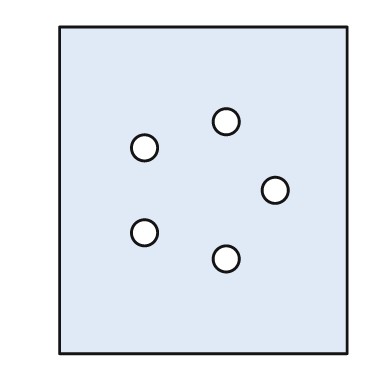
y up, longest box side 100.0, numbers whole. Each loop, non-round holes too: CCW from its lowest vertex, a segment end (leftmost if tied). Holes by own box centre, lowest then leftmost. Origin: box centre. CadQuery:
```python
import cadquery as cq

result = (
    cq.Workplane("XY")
    .moveTo(-44.0, -50.0)
    .lineTo(44.0, -50.0)
    .lineTo(44.0, 50.0)
    .lineTo(-44.0, 50.0)
    .close()
    .moveTo(7.0, -21.0)
    .circle(4.0)
    .moveTo(-18.0, -13.0)
    .circle(4.0)
    .moveTo(22.0, 0.0)
    .circle(4.0)
    .moveTo(-18.0, 13.0)
    .circle(4.0)
    .moveTo(7.0, 21.0)
    .circle(4.0)
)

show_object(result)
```